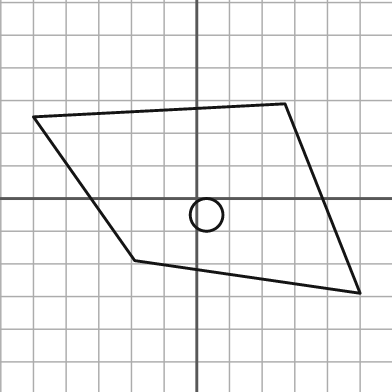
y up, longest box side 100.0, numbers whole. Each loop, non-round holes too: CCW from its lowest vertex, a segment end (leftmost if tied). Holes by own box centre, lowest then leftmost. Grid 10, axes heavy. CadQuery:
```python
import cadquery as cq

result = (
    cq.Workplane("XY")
    .moveTo(50.0, -29.0)
    .lineTo(27.0, 29.0)
    .lineTo(-50.0, 25.0)
    .lineTo(-19.0, -19.0)
    .close()
    .moveTo(3.0, -5.0)
    .circle(5.0)
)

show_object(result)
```